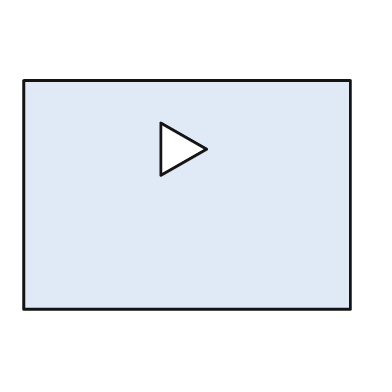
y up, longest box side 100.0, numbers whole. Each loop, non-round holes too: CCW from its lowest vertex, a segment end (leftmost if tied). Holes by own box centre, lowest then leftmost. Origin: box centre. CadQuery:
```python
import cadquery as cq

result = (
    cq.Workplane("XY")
    .moveTo(-50.0, -35.0)
    .lineTo(50.0, -35.0)
    .lineTo(50.0, 35.0)
    .lineTo(-50.0, 35.0)
    .close()
    .moveTo(-8.0, 6.0)
    .lineTo(6.0, 14.0)
    .lineTo(-8.0, 22.0)
    .close()
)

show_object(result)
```